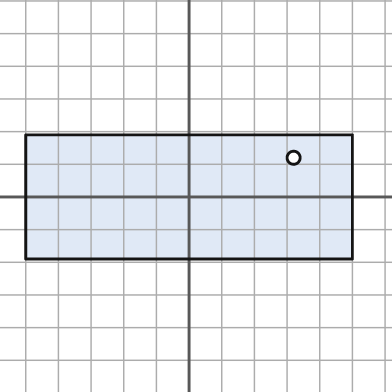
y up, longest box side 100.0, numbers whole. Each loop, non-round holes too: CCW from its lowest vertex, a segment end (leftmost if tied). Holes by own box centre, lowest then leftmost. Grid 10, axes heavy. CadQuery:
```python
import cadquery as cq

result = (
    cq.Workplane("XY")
    .moveTo(-50.0, -19.0)
    .lineTo(50.0, -19.0)
    .lineTo(50.0, 19.0)
    .lineTo(-50.0, 19.0)
    .close()
    .moveTo(32.0, 12.0)
    .circle(2.0)
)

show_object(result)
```